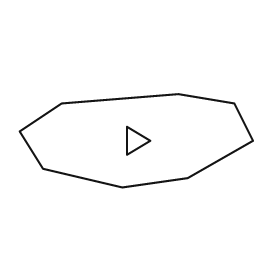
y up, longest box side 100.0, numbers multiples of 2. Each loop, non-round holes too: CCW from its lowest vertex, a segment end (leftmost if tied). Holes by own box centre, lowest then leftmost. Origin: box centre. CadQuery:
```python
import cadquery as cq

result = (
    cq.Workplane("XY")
    .moveTo(-6.0, -20.0)
    .lineTo(22.0, -16.0)
    .lineTo(50.0, 0.0)
    .lineTo(42.0, 16.0)
    .lineTo(18.0, 20.0)
    .lineTo(-32.0, 16.0)
    .lineTo(-50.0, 4.0)
    .lineTo(-40.0, -12.0)
    .close()
    .moveTo(-4.0, -6.0)
    .lineTo(6.0, 0.0)
    .lineTo(-4.0, 6.0)
    .close()
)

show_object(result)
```